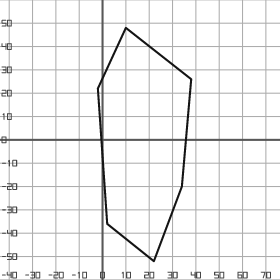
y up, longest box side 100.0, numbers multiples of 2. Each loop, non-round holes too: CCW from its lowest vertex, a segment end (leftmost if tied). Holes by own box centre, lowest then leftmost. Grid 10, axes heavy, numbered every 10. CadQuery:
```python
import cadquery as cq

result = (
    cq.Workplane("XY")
    .moveTo(22.0, -52.0)
    .lineTo(34.0, -20.0)
    .lineTo(38.0, 26.0)
    .lineTo(10.0, 48.0)
    .lineTo(-2.0, 22.0)
    .lineTo(2.0, -36.0)
    .close()
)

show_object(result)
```